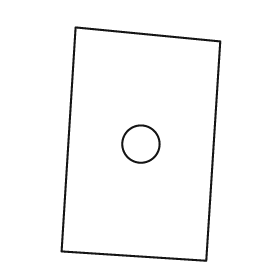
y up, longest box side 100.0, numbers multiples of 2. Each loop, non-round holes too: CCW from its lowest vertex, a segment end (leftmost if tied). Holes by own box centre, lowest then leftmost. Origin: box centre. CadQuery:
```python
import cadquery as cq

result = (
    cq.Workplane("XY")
    .moveTo(28.0, -50.0)
    .lineTo(34.0, 44.0)
    .lineTo(-28.0, 50.0)
    .lineTo(-34.0, -46.0)
    .close()
    .moveTo(0.0, 0.0)
    .circle(8.0)
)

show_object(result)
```